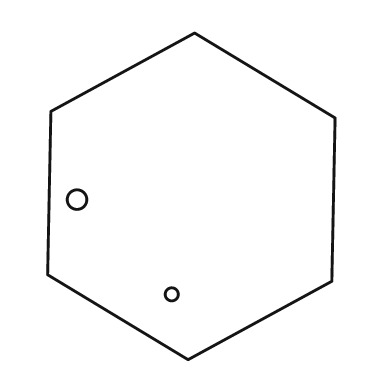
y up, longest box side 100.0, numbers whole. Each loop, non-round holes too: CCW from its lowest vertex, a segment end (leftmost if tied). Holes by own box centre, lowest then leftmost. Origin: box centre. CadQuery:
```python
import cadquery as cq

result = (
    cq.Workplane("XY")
    .moveTo(-1.0, -50.0)
    .lineTo(43.0, -26.0)
    .lineTo(44.0, 24.0)
    .lineTo(1.0, 50.0)
    .lineTo(-43.0, 26.0)
    .lineTo(-44.0, -24.0)
    .close()
    .moveTo(-6.0, -30.0)
    .circle(2.0)
    .moveTo(-35.0, -1.0)
    .circle(3.0)
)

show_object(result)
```